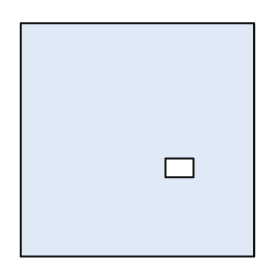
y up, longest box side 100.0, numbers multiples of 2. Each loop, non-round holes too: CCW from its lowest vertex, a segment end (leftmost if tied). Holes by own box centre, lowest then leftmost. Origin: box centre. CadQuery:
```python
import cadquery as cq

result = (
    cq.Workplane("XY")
    .moveTo(-50.0, -50.0)
    .lineTo(50.0, -50.0)
    .lineTo(50.0, 50.0)
    .lineTo(-50.0, 50.0)
    .close()
    .moveTo(12.0, -16.0)
    .lineTo(24.0, -16.0)
    .lineTo(24.0, -8.0)
    .lineTo(12.0, -8.0)
    .close()
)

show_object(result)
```